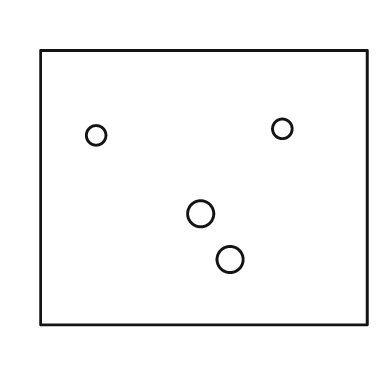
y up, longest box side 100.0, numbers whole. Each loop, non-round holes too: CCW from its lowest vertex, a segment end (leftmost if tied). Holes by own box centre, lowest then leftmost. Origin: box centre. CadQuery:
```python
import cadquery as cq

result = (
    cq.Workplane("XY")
    .moveTo(-50.0, -42.0)
    .lineTo(50.0, -42.0)
    .lineTo(50.0, 42.0)
    .lineTo(-50.0, 42.0)
    .close()
    .moveTo(8.0, -22.0)
    .circle(4.0)
    .moveTo(-1.0, -8.0)
    .circle(4.0)
    .moveTo(-33.0, 16.0)
    .circle(3.0)
    .moveTo(24.0, 18.0)
    .circle(3.0)
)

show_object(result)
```